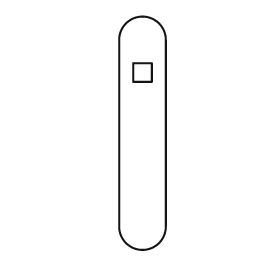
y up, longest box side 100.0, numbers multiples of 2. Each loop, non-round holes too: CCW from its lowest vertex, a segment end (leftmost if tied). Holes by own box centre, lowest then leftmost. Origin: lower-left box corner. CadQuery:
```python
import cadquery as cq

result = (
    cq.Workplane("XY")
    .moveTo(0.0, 10.0)
    .threePointArc((10.0, 0.0), (20.0, 10.0))
    .lineTo(20.0, 90.0)
    .threePointArc((10.0, 100.0), (0.0, 90.0))
    .close()
    .moveTo(6.0, 72.0)
    .lineTo(14.0, 72.0)
    .lineTo(14.0, 80.0)
    .lineTo(6.0, 80.0)
    .close()
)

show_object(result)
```